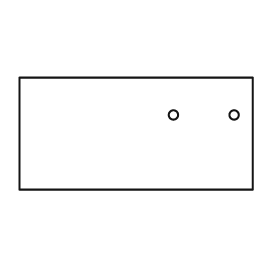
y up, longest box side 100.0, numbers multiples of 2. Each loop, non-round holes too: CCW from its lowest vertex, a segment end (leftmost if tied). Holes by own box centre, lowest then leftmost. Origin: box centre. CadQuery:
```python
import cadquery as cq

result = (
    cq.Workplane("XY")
    .moveTo(-50.0, -24.0)
    .lineTo(50.0, -24.0)
    .lineTo(50.0, 24.0)
    .lineTo(-50.0, 24.0)
    .close()
    .moveTo(16.0, 8.0)
    .circle(2.0)
    .moveTo(42.0, 8.0)
    .circle(2.0)
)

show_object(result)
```